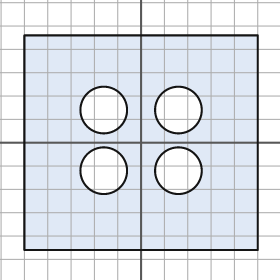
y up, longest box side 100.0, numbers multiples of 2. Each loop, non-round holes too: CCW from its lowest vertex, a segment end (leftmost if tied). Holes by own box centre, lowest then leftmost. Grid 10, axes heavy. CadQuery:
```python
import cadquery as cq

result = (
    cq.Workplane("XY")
    .moveTo(-50.0, -46.0)
    .lineTo(50.0, -46.0)
    .lineTo(50.0, 46.0)
    .lineTo(-50.0, 46.0)
    .close()
    .moveTo(-16.0, -12.0)
    .circle(10.0)
    .moveTo(16.0, -12.0)
    .circle(10.0)
    .moveTo(-16.0, 14.0)
    .circle(10.0)
    .moveTo(16.0, 14.0)
    .circle(10.0)
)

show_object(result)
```